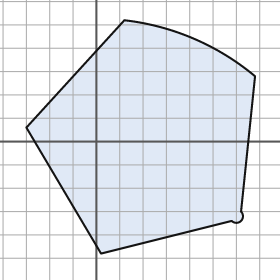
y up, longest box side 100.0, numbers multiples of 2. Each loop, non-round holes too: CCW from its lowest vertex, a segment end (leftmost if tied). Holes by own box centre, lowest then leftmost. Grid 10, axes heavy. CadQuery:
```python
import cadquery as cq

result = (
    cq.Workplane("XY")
    .moveTo(2.0, -48.0)
    .lineTo(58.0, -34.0)
    .threePointArc((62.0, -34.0), (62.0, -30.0))
    .lineTo(68.0, 28.0)
    .threePointArc((42.0, 44.0), (12.0, 52.0))
    .lineTo(-30.0, 6.0)
    .close()
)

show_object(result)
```